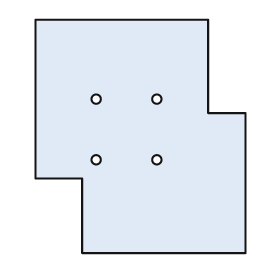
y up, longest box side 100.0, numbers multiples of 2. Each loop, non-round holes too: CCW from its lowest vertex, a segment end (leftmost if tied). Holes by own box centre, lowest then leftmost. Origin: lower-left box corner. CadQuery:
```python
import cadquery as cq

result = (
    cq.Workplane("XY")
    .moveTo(20.0, 0.0)
    .lineTo(90.0, 0.0)
    .lineTo(90.0, 60.0)
    .lineTo(74.0, 60.0)
    .lineTo(74.0, 100.0)
    .lineTo(0.0, 100.0)
    .lineTo(0.0, 32.0)
    .lineTo(20.0, 32.0)
    .close()
    .moveTo(26.0, 40.0)
    .circle(2.0)
    .moveTo(52.0, 40.0)
    .circle(2.0)
    .moveTo(26.0, 66.0)
    .circle(2.0)
    .moveTo(52.0, 66.0)
    .circle(2.0)
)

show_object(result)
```